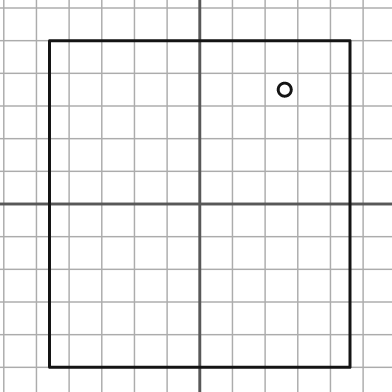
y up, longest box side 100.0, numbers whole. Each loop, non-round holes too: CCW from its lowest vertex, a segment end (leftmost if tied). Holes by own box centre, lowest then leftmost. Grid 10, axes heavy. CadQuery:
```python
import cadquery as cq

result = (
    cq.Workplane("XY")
    .moveTo(-46.0, -50.0)
    .lineTo(46.0, -50.0)
    .lineTo(46.0, 50.0)
    .lineTo(-46.0, 50.0)
    .close()
    .moveTo(26.0, 35.0)
    .circle(2.0)
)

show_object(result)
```